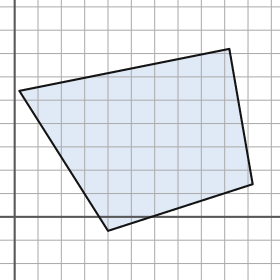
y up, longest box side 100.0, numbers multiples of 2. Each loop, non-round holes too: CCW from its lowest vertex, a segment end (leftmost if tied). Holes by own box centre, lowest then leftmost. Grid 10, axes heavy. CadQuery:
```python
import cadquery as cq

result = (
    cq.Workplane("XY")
    .moveTo(40.0, -6.0)
    .lineTo(102.0, 14.0)
    .lineTo(92.0, 72.0)
    .lineTo(2.0, 54.0)
    .close()
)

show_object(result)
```